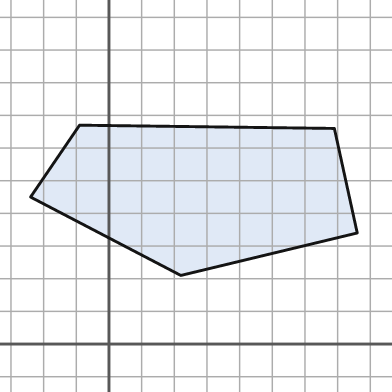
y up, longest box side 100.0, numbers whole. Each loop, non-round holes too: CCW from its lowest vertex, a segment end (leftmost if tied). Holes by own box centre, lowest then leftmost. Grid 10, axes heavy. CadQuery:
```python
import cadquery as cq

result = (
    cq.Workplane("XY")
    .moveTo(22.0, 21.0)
    .lineTo(76.0, 34.0)
    .lineTo(69.0, 66.0)
    .lineTo(-9.0, 67.0)
    .lineTo(-24.0, 45.0)
    .close()
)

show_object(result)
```